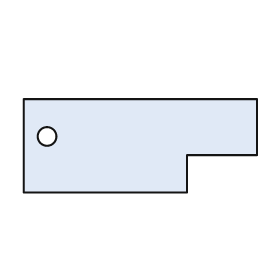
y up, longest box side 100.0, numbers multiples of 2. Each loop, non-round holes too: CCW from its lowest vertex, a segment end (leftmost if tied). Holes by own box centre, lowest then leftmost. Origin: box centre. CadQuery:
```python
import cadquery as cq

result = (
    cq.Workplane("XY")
    .moveTo(-50.0, -20.0)
    .lineTo(20.0, -20.0)
    .lineTo(20.0, -4.0)
    .lineTo(50.0, -4.0)
    .lineTo(50.0, 20.0)
    .lineTo(-50.0, 20.0)
    .close()
    .moveTo(-40.0, 4.0)
    .circle(4.0)
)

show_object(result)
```